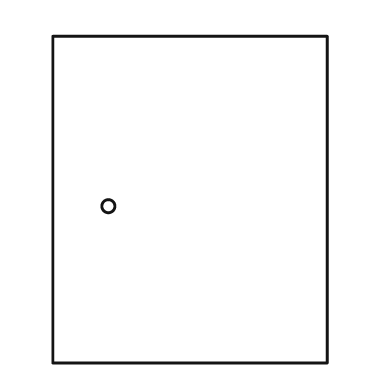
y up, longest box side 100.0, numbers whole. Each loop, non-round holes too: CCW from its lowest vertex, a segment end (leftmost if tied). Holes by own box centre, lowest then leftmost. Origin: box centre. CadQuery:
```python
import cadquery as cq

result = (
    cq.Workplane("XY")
    .moveTo(-42.0, -50.0)
    .lineTo(42.0, -50.0)
    .lineTo(42.0, 50.0)
    .lineTo(-42.0, 50.0)
    .close()
    .moveTo(-25.0, -2.0)
    .circle(2.0)
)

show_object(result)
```